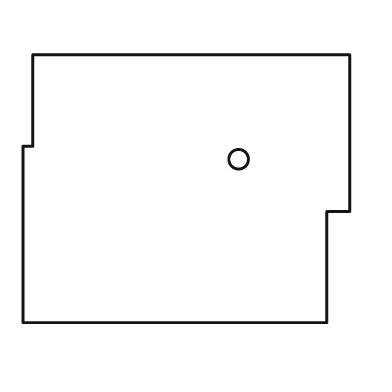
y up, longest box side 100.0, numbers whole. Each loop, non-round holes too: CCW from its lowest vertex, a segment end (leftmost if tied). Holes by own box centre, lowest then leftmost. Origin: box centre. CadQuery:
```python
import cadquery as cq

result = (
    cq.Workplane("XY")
    .moveTo(-50.0, -41.0)
    .lineTo(43.0, -41.0)
    .lineTo(43.0, -7.0)
    .lineTo(50.0, -7.0)
    .lineTo(50.0, 41.0)
    .lineTo(-47.0, 41.0)
    .lineTo(-47.0, 13.0)
    .lineTo(-50.0, 13.0)
    .close()
    .moveTo(16.0, 9.0)
    .circle(3.0)
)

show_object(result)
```